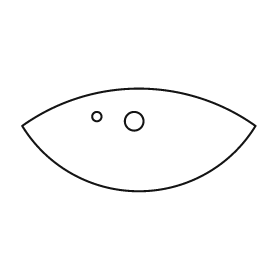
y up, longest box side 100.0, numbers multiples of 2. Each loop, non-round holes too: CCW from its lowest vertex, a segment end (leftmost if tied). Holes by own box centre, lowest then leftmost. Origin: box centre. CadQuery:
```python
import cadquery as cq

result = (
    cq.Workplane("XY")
    .moveTo(-50.0, 6.0)
    .threePointArc((0.0, -22.0), (50.0, 6.0))
    .threePointArc((0.0, 22.0), (-50.0, 6.0))
    .close()
    .moveTo(-2.0, 8.0)
    .circle(4.0)
    .moveTo(-18.0, 10.0)
    .circle(2.0)
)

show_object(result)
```